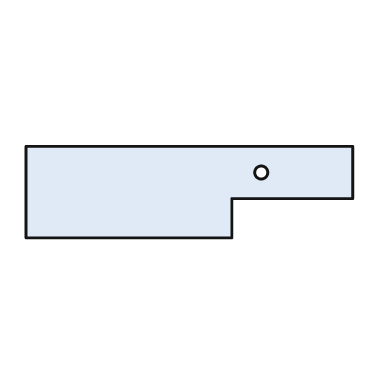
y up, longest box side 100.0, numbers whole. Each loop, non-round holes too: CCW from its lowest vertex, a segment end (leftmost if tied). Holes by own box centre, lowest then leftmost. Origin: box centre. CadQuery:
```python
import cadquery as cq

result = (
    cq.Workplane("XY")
    .moveTo(-50.0, -14.0)
    .lineTo(13.0, -14.0)
    .lineTo(13.0, -2.0)
    .lineTo(50.0, -2.0)
    .lineTo(50.0, 14.0)
    .lineTo(-50.0, 14.0)
    .close()
    .moveTo(22.0, 6.0)
    .circle(2.0)
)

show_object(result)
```